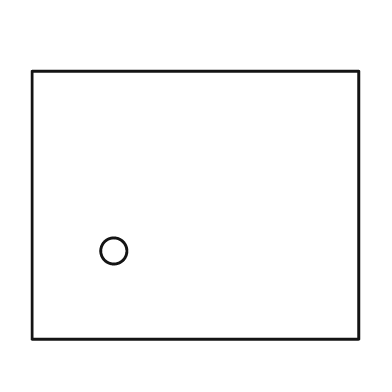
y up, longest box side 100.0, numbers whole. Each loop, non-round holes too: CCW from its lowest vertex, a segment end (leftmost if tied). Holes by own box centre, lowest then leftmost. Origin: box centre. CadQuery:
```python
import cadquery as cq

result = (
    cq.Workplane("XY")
    .moveTo(-50.0, -41.0)
    .lineTo(50.0, -41.0)
    .lineTo(50.0, 41.0)
    .lineTo(-50.0, 41.0)
    .close()
    .moveTo(-25.0, -14.0)
    .circle(4.0)
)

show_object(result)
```